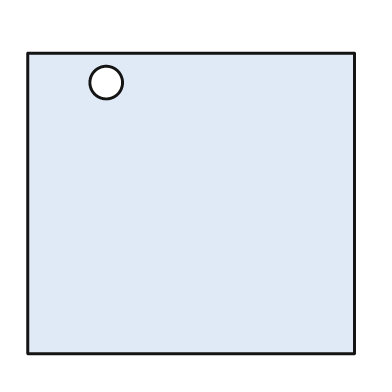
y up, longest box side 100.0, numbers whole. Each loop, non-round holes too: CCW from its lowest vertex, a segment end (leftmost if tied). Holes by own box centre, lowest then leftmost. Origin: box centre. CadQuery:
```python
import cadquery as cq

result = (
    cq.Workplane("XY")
    .moveTo(-50.0, -46.0)
    .lineTo(50.0, -46.0)
    .lineTo(50.0, 46.0)
    .lineTo(-50.0, 46.0)
    .close()
    .moveTo(-26.0, 37.0)
    .circle(5.0)
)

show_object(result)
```